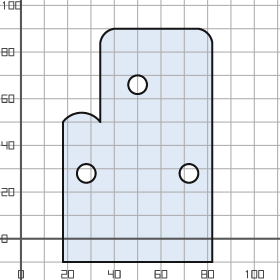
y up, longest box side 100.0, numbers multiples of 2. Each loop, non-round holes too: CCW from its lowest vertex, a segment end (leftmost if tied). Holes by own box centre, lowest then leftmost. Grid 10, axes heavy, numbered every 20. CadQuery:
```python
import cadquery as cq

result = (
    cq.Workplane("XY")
    .moveTo(18.0, -10.0)
    .lineTo(82.0, -10.0)
    .lineTo(82.0, 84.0)
    .threePointArc((80.0, 88.0), (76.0, 90.0))
    .lineTo(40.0, 90.0)
    .threePointArc((36.0, 88.0), (34.0, 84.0))
    .lineTo(34.0, 50.0)
    .threePointArc((26.0, 54.0), (18.0, 50.0))
    .close()
    .moveTo(28.0, 28.0)
    .circle(4.0)
    .moveTo(72.0, 28.0)
    .circle(4.0)
    .moveTo(50.0, 66.0)
    .circle(4.0)
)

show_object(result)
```